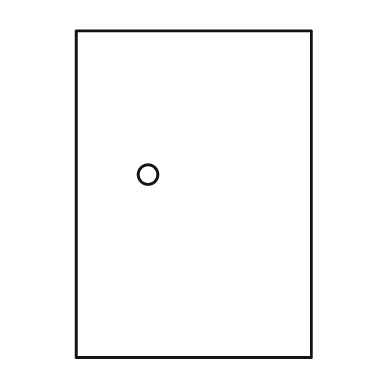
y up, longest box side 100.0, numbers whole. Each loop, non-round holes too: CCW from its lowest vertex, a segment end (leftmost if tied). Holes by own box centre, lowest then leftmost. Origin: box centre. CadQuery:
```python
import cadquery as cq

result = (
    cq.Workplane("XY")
    .moveTo(-36.0, -50.0)
    .lineTo(36.0, -50.0)
    .lineTo(36.0, 50.0)
    .lineTo(-36.0, 50.0)
    .close()
    .moveTo(-14.0, 6.0)
    .circle(3.0)
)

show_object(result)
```